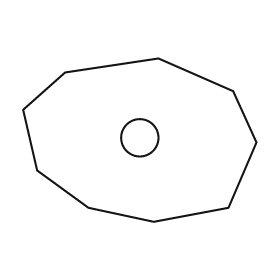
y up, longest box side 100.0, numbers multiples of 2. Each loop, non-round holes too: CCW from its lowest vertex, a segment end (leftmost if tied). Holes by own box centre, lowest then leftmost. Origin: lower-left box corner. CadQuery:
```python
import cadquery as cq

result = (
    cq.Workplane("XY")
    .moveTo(56.0, 0.0)
    .lineTo(88.0, 6.0)
    .lineTo(100.0, 34.0)
    .lineTo(90.0, 56.0)
    .lineTo(58.0, 70.0)
    .lineTo(18.0, 64.0)
    .lineTo(0.0, 48.0)
    .lineTo(6.0, 22.0)
    .lineTo(28.0, 6.0)
    .close()
    .moveTo(50.0, 36.0)
    .circle(8.0)
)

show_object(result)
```